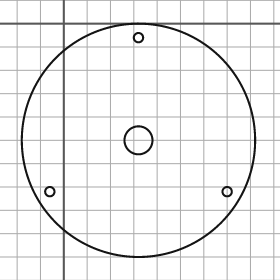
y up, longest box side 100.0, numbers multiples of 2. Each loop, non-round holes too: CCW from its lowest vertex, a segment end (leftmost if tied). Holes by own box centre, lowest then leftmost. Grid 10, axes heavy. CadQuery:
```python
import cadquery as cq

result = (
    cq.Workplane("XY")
    .moveTo(32.0, -50.0)
    .circle(50.0)
    .moveTo(-6.0, -72.0)
    .circle(2.0)
    .moveTo(70.0, -72.0)
    .circle(2.0)
    .moveTo(32.0, -50.0)
    .circle(6.0)
    .moveTo(32.0, -6.0)
    .circle(2.0)
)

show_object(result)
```